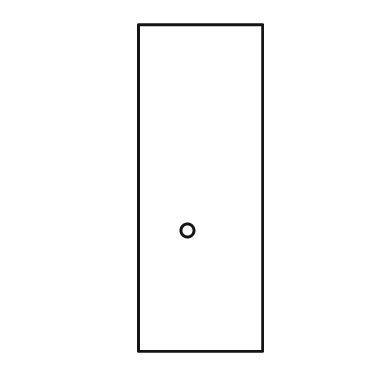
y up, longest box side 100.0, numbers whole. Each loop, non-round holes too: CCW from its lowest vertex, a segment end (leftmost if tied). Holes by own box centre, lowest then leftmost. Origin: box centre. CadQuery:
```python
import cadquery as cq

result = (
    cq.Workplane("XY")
    .moveTo(-19.0, -50.0)
    .lineTo(19.0, -50.0)
    .lineTo(19.0, 50.0)
    .lineTo(-19.0, 50.0)
    .close()
    .moveTo(-4.0, -13.0)
    .circle(2.0)
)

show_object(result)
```